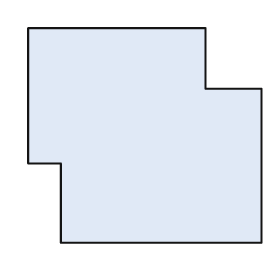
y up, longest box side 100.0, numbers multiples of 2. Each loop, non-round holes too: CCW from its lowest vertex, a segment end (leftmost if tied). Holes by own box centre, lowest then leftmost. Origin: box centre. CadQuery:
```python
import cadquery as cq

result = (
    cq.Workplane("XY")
    .moveTo(-36.0, -46.0)
    .lineTo(50.0, -46.0)
    .lineTo(50.0, 20.0)
    .lineTo(26.0, 20.0)
    .lineTo(26.0, 46.0)
    .lineTo(-50.0, 46.0)
    .lineTo(-50.0, -12.0)
    .lineTo(-36.0, -12.0)
    .close()
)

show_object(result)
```